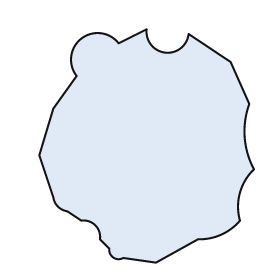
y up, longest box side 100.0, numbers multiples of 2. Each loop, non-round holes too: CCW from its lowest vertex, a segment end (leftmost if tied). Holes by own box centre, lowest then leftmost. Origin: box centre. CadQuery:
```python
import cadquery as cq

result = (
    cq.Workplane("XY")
    .moveTo(4.0, -50.0)
    .lineTo(22.0, -40.0)
    .threePointArc((32.0, -38.0), (40.0, -32.0))
    .threePointArc((40.0, -20.0), (46.0, -10.0))
    .threePointArc((42.0, 4.0), (44.0, 18.0))
    .lineTo(36.0, 36.0)
    .lineTo(18.0, 48.0)
    .threePointArc((8.0, 40.0), (0.0, 50.0))
    .lineTo(-12.0, 44.0)
    .threePointArc((-28.0, 46.0), (-30.0, 30.0))
    .lineTo(-40.0, 16.0)
    .lineTo(-46.0, -4.0)
    .lineTo(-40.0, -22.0)
    .threePointArc((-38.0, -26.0), (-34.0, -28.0))
    .lineTo(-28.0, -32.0)
    .threePointArc((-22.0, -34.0), (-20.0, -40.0))
    .lineTo(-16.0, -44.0)
    .threePointArc((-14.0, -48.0), (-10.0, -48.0))
    .close()
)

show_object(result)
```